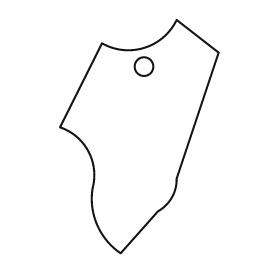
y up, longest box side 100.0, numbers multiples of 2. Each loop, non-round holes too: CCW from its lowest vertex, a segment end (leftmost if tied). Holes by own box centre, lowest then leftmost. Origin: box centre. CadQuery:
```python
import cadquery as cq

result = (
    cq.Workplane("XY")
    .moveTo(-8.0, -50.0)
    .lineTo(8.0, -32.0)
    .threePointArc((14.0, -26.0), (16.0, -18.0))
    .lineTo(34.0, 36.0)
    .lineTo(16.0, 50.0)
    .threePointArc((2.0, 38.0), (-16.0, 40.0))
    .lineTo(-34.0, 4.0)
    .threePointArc((-22.0, -6.0), (-20.0, -22.0))
    .threePointArc((-18.0, -38.0), (-8.0, -50.0))
    .close()
    .moveTo(2.0, 30.0)
    .circle(4.0)
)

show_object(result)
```